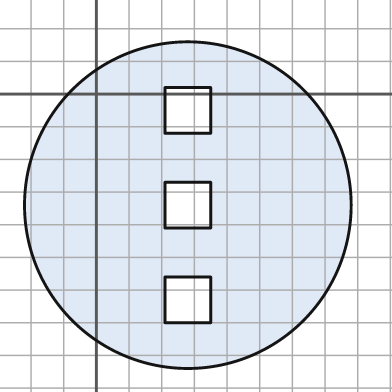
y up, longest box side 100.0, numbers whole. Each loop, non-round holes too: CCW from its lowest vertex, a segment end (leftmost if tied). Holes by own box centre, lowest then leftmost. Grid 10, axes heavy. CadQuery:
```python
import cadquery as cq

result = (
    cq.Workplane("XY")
    .moveTo(28.0, -34.0)
    .circle(50.0)
    .moveTo(21.0, -70.0)
    .lineTo(35.0, -70.0)
    .lineTo(35.0, -56.0)
    .lineTo(21.0, -56.0)
    .close()
    .moveTo(21.0, -41.0)
    .lineTo(35.0, -41.0)
    .lineTo(35.0, -27.0)
    .lineTo(21.0, -27.0)
    .close()
    .moveTo(21.0, -12.0)
    .lineTo(35.0, -12.0)
    .lineTo(35.0, 2.0)
    .lineTo(21.0, 2.0)
    .close()
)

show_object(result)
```